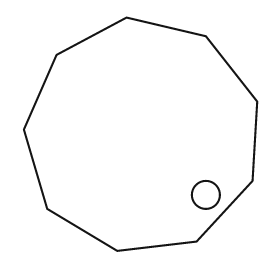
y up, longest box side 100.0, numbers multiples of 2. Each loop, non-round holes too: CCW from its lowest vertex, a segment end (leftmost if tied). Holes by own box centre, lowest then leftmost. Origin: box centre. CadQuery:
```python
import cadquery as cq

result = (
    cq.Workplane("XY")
    .moveTo(-10.0, -50.0)
    .lineTo(24.0, -46.0)
    .lineTo(48.0, -20.0)
    .lineTo(50.0, 14.0)
    .lineTo(28.0, 42.0)
    .lineTo(-6.0, 50.0)
    .lineTo(-36.0, 34.0)
    .lineTo(-50.0, 2.0)
    .lineTo(-40.0, -32.0)
    .close()
    .moveTo(28.0, -26.0)
    .circle(6.0)
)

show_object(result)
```